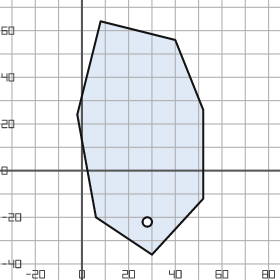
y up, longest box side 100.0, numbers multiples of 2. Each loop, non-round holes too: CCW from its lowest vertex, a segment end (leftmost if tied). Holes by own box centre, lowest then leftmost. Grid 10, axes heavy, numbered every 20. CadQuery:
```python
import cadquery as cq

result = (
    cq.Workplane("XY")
    .moveTo(30.0, -36.0)
    .lineTo(52.0, -12.0)
    .lineTo(52.0, 26.0)
    .lineTo(40.0, 56.0)
    .lineTo(8.0, 64.0)
    .lineTo(-2.0, 24.0)
    .lineTo(6.0, -20.0)
    .close()
    .moveTo(28.0, -22.0)
    .circle(2.0)
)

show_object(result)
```